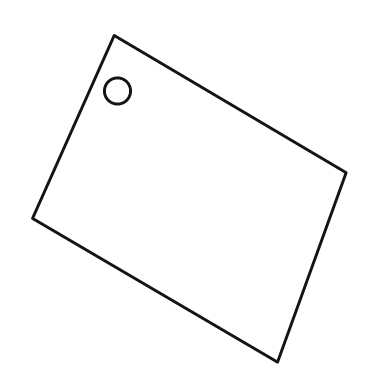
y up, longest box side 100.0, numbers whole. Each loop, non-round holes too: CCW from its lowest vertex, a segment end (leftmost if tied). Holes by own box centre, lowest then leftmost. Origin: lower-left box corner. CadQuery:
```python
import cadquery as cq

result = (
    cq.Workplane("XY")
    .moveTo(75.0, 0.0)
    .lineTo(96.0, 58.0)
    .lineTo(25.0, 100.0)
    .lineTo(0.0, 44.0)
    .close()
    .moveTo(26.0, 83.0)
    .circle(4.0)
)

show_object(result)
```